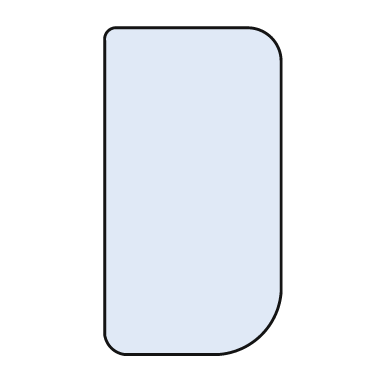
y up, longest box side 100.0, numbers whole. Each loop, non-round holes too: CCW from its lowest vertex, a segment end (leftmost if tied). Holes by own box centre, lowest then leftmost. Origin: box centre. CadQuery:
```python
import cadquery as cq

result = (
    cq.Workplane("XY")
    .moveTo(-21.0, -50.0)
    .lineTo(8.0, -50.0)
    .threePointArc((21.0, -44.0), (27.0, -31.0))
    .lineTo(27.0, 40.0)
    .threePointArc((24.0, 47.0), (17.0, 50.0))
    .lineTo(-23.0, 50.0)
    .threePointArc((-26.0, 49.0), (-27.0, 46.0))
    .lineTo(-27.0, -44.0)
    .threePointArc((-25.0, -48.0), (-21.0, -50.0))
    .close()
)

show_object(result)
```